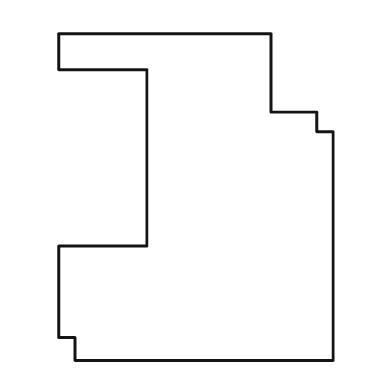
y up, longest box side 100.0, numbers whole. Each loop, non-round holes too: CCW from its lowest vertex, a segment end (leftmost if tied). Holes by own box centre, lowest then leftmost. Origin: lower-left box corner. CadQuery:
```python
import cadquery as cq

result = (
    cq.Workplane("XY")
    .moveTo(5.0, 0.0)
    .lineTo(84.0, 0.0)
    .lineTo(84.0, 70.0)
    .lineTo(79.0, 70.0)
    .lineTo(79.0, 76.0)
    .lineTo(65.0, 76.0)
    .lineTo(65.0, 100.0)
    .lineTo(0.0, 100.0)
    .lineTo(0.0, 89.0)
    .lineTo(27.0, 89.0)
    .lineTo(27.0, 35.0)
    .lineTo(0.0, 35.0)
    .lineTo(0.0, 7.0)
    .lineTo(5.0, 7.0)
    .close()
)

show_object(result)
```